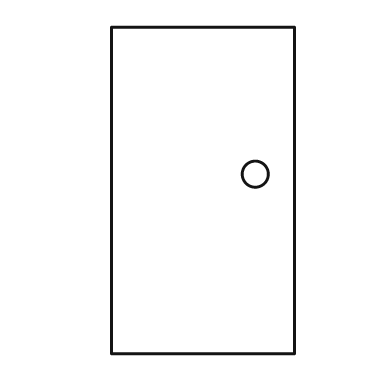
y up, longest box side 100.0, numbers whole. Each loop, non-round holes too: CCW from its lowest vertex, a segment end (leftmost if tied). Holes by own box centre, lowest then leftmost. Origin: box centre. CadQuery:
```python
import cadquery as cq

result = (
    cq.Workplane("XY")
    .moveTo(-28.0, -50.0)
    .lineTo(28.0, -50.0)
    .lineTo(28.0, 50.0)
    .lineTo(-28.0, 50.0)
    .close()
    .moveTo(16.0, 5.0)
    .circle(4.0)
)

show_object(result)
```